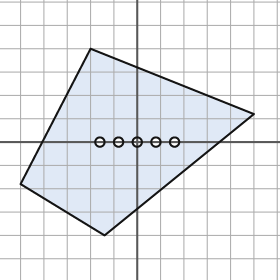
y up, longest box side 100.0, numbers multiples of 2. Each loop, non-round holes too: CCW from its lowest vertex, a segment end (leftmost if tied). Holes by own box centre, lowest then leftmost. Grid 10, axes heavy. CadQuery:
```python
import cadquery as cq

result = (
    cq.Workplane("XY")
    .moveTo(-14.0, -40.0)
    .lineTo(50.0, 12.0)
    .lineTo(-20.0, 40.0)
    .lineTo(-50.0, -18.0)
    .close()
    .moveTo(-16.0, 0.0)
    .circle(2.0)
    .moveTo(-8.0, 0.0)
    .circle(2.0)
    .moveTo(0.0, 0.0)
    .circle(2.0)
    .moveTo(8.0, 0.0)
    .circle(2.0)
    .moveTo(16.0, 0.0)
    .circle(2.0)
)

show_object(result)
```